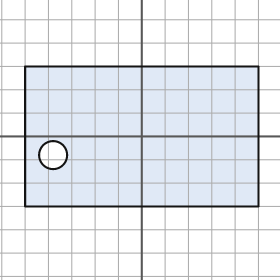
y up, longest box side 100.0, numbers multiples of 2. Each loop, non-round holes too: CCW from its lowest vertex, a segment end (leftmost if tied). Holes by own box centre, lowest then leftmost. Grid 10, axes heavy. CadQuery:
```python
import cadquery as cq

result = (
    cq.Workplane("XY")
    .moveTo(-50.0, -30.0)
    .lineTo(50.0, -30.0)
    .lineTo(50.0, 30.0)
    .lineTo(-50.0, 30.0)
    .close()
    .moveTo(-38.0, -8.0)
    .circle(6.0)
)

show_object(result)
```